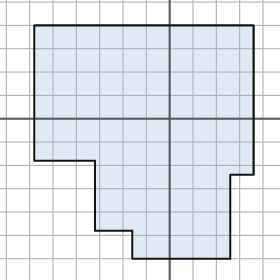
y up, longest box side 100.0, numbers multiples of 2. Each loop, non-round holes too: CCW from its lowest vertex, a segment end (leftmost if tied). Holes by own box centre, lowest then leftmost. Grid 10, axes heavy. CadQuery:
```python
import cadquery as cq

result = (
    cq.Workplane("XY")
    .moveTo(-16.0, -60.0)
    .lineTo(26.0, -60.0)
    .lineTo(26.0, -24.0)
    .lineTo(36.0, -24.0)
    .lineTo(36.0, 40.0)
    .lineTo(-58.0, 40.0)
    .lineTo(-58.0, -18.0)
    .lineTo(-32.0, -18.0)
    .lineTo(-32.0, -48.0)
    .lineTo(-16.0, -48.0)
    .close()
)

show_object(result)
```